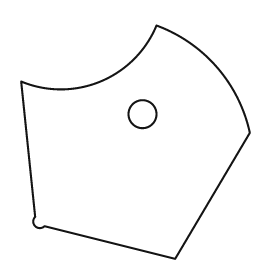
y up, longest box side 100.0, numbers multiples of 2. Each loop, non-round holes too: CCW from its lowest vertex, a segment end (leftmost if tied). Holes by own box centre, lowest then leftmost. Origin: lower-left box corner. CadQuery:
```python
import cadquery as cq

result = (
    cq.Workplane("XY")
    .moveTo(66.0, 0.0)
    .lineTo(98.0, 54.0)
    .threePointArc((84.0, 82.0), (58.0, 100.0))
    .threePointArc((34.0, 76.0), (0.0, 76.0))
    .lineTo(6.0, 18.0)
    .threePointArc((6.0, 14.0), (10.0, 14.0))
    .close()
    .moveTo(52.0, 62.0)
    .circle(6.0)
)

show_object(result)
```